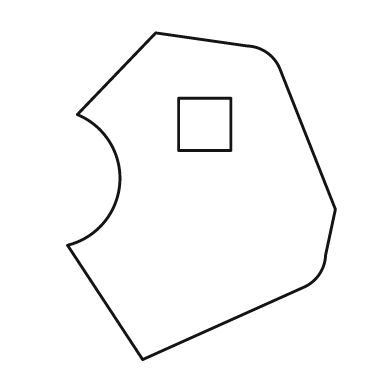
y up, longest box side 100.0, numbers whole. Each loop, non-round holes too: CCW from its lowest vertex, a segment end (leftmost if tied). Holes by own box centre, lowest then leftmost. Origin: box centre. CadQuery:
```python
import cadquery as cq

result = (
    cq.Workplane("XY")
    .moveTo(-18.0, -50.0)
    .lineTo(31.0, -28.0)
    .threePointArc((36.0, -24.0), (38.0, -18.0))
    .lineTo(41.0, -4.0)
    .lineTo(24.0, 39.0)
    .threePointArc((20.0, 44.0), (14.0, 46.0))
    .lineTo(-14.0, 50.0)
    .lineTo(-38.0, 25.0)
    .threePointArc((-25.0, 4.0), (-41.0, -15.0))
    .close()
    .moveTo(-7.0, 14.0)
    .lineTo(9.0, 14.0)
    .lineTo(9.0, 30.0)
    .lineTo(-7.0, 30.0)
    .close()
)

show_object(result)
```